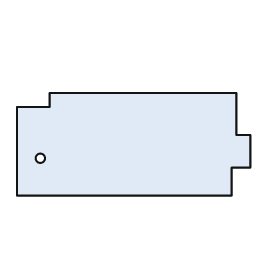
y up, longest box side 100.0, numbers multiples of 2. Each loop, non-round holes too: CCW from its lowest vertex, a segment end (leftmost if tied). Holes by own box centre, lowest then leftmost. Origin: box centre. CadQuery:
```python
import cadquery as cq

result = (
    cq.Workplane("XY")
    .moveTo(-50.0, -22.0)
    .lineTo(42.0, -22.0)
    .lineTo(42.0, -10.0)
    .lineTo(50.0, -10.0)
    .lineTo(50.0, 4.0)
    .lineTo(44.0, 4.0)
    .lineTo(44.0, 22.0)
    .lineTo(-36.0, 22.0)
    .lineTo(-36.0, 16.0)
    .lineTo(-50.0, 16.0)
    .close()
    .moveTo(-40.0, -6.0)
    .circle(2.0)
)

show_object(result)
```